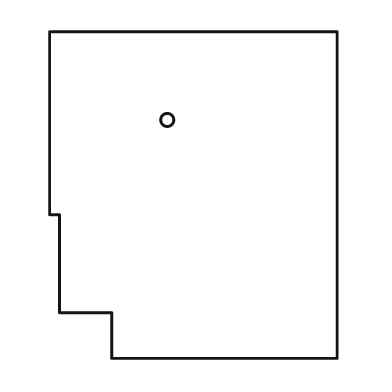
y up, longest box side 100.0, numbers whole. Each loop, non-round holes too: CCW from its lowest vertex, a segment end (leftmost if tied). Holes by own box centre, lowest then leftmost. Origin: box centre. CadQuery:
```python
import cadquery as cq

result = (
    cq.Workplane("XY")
    .moveTo(-25.0, -50.0)
    .lineTo(44.0, -50.0)
    .lineTo(44.0, 50.0)
    .lineTo(-44.0, 50.0)
    .lineTo(-44.0, -6.0)
    .lineTo(-41.0, -6.0)
    .lineTo(-41.0, -36.0)
    .lineTo(-25.0, -36.0)
    .close()
    .moveTo(-8.0, 23.0)
    .circle(2.0)
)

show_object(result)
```